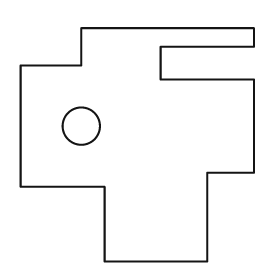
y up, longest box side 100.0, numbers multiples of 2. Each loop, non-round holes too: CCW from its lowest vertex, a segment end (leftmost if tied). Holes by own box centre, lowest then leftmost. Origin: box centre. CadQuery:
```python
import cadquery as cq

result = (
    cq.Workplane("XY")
    .moveTo(-14.0, -50.0)
    .lineTo(30.0, -50.0)
    .lineTo(30.0, -12.0)
    .lineTo(50.0, -12.0)
    .lineTo(50.0, 28.0)
    .lineTo(10.0, 28.0)
    .lineTo(10.0, 42.0)
    .lineTo(50.0, 42.0)
    .lineTo(50.0, 50.0)
    .lineTo(-24.0, 50.0)
    .lineTo(-24.0, 34.0)
    .lineTo(-50.0, 34.0)
    .lineTo(-50.0, -18.0)
    .lineTo(-14.0, -18.0)
    .close()
    .moveTo(-24.0, 8.0)
    .circle(8.0)
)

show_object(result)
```